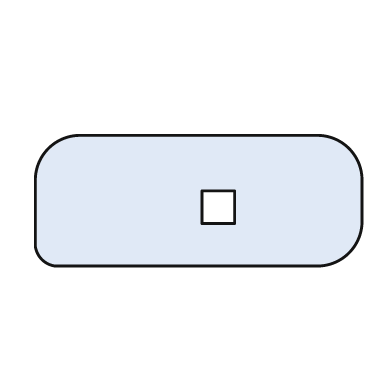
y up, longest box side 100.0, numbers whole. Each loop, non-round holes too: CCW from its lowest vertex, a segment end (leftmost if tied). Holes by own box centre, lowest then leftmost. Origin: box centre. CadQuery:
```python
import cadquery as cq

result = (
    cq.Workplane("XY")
    .moveTo(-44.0, -20.0)
    .lineTo(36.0, -20.0)
    .threePointArc((46.0, -16.0), (50.0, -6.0))
    .lineTo(50.0, 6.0)
    .threePointArc((46.0, 16.0), (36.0, 20.0))
    .lineTo(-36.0, 20.0)
    .threePointArc((-46.0, 16.0), (-50.0, 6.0))
    .lineTo(-50.0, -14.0)
    .threePointArc((-48.0, -18.0), (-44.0, -20.0))
    .close()
    .moveTo(1.0, -7.0)
    .lineTo(11.0, -7.0)
    .lineTo(11.0, 3.0)
    .lineTo(1.0, 3.0)
    .close()
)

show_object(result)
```